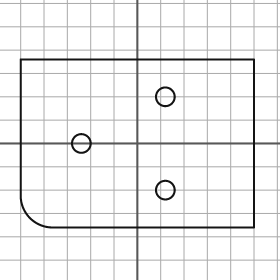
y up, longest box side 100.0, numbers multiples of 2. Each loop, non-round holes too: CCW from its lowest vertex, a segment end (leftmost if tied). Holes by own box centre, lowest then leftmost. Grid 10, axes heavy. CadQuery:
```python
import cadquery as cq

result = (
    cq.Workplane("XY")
    .moveTo(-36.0, -36.0)
    .lineTo(50.0, -36.0)
    .lineTo(50.0, 36.0)
    .lineTo(-50.0, 36.0)
    .lineTo(-50.0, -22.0)
    .threePointArc((-46.0, -32.0), (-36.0, -36.0))
    .close()
    .moveTo(12.0, -20.0)
    .circle(4.0)
    .moveTo(-24.0, 0.0)
    .circle(4.0)
    .moveTo(12.0, 20.0)
    .circle(4.0)
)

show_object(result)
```